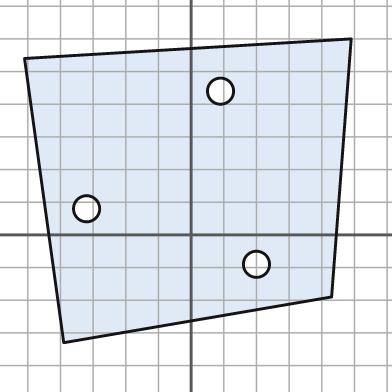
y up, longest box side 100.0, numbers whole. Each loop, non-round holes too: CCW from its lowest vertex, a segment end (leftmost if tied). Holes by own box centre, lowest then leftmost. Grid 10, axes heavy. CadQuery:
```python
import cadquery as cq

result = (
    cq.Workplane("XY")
    .moveTo(-39.0, -33.0)
    .lineTo(43.0, -19.0)
    .lineTo(49.0, 60.0)
    .lineTo(-51.0, 54.0)
    .close()
    .moveTo(20.0, -9.0)
    .circle(4.0)
    .moveTo(-32.0, 8.0)
    .circle(4.0)
    .moveTo(9.0, 44.0)
    .circle(4.0)
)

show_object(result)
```